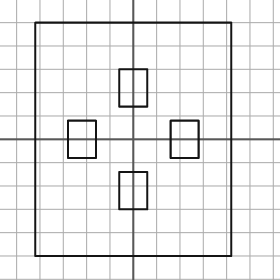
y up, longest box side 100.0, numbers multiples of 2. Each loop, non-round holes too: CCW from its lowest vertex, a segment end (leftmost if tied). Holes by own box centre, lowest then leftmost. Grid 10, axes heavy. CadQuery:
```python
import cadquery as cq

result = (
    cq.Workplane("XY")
    .moveTo(-42.0, -50.0)
    .lineTo(42.0, -50.0)
    .lineTo(42.0, 50.0)
    .lineTo(-42.0, 50.0)
    .close()
    .moveTo(-6.0, -30.0)
    .lineTo(6.0, -30.0)
    .lineTo(6.0, -14.0)
    .lineTo(-6.0, -14.0)
    .close()
    .moveTo(-28.0, -8.0)
    .lineTo(-16.0, -8.0)
    .lineTo(-16.0, 8.0)
    .lineTo(-28.0, 8.0)
    .close()
    .moveTo(16.0, -8.0)
    .lineTo(28.0, -8.0)
    .lineTo(28.0, 8.0)
    .lineTo(16.0, 8.0)
    .close()
    .moveTo(-6.0, 14.0)
    .lineTo(6.0, 14.0)
    .lineTo(6.0, 30.0)
    .lineTo(-6.0, 30.0)
    .close()
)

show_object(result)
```